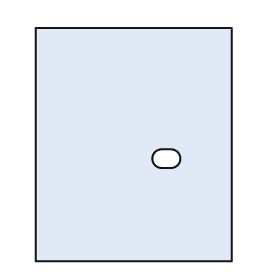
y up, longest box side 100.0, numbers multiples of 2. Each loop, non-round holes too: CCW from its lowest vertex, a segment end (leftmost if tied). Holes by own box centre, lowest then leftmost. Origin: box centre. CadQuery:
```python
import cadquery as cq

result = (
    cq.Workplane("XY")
    .moveTo(-42.0, -50.0)
    .lineTo(42.0, -50.0)
    .lineTo(42.0, 50.0)
    .lineTo(-42.0, 50.0)
    .close()
    .moveTo(12.0, -10.0)
    .lineTo(16.0, -10.0)
    .threePointArc((20.0, -6.0), (16.0, -2.0))
    .lineTo(12.0, -2.0)
    .threePointArc((8.0, -6.0), (12.0, -10.0))
    .close()
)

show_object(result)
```